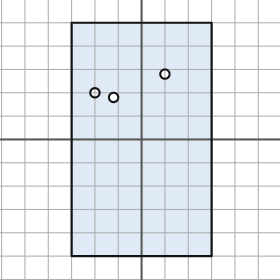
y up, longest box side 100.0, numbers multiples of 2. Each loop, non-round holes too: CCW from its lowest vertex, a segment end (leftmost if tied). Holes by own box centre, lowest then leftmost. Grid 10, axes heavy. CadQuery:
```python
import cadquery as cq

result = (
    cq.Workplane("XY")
    .moveTo(-30.0, -50.0)
    .lineTo(30.0, -50.0)
    .lineTo(30.0, 50.0)
    .lineTo(-30.0, 50.0)
    .close()
    .moveTo(-12.0, 18.0)
    .circle(2.0)
    .moveTo(-20.0, 20.0)
    .circle(2.0)
    .moveTo(10.0, 28.0)
    .circle(2.0)
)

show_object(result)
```